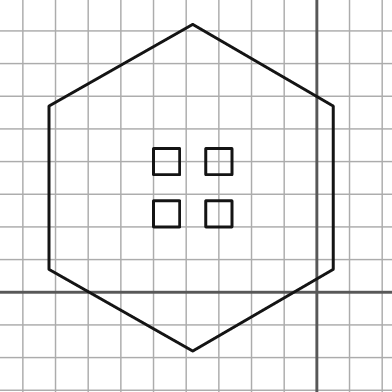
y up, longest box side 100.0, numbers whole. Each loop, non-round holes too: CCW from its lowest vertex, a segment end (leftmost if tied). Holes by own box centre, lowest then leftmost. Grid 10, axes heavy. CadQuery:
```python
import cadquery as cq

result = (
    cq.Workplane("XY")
    .moveTo(-38.0, -18.0)
    .lineTo(5.0, 7.0)
    .lineTo(5.0, 57.0)
    .lineTo(-38.0, 82.0)
    .lineTo(-82.0, 57.0)
    .lineTo(-82.0, 7.0)
    .close()
    .moveTo(-50.0, 20.0)
    .lineTo(-42.0, 20.0)
    .lineTo(-42.0, 28.0)
    .lineTo(-50.0, 28.0)
    .close()
    .moveTo(-34.0, 20.0)
    .lineTo(-26.0, 20.0)
    .lineTo(-26.0, 28.0)
    .lineTo(-34.0, 28.0)
    .close()
    .moveTo(-50.0, 36.0)
    .lineTo(-42.0, 36.0)
    .lineTo(-42.0, 44.0)
    .lineTo(-50.0, 44.0)
    .close()
    .moveTo(-34.0, 36.0)
    .lineTo(-26.0, 36.0)
    .lineTo(-26.0, 44.0)
    .lineTo(-34.0, 44.0)
    .close()
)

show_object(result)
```